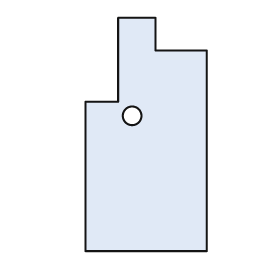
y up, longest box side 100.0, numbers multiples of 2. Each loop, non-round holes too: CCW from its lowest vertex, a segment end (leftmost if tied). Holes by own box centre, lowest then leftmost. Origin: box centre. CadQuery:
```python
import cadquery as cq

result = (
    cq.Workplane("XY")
    .moveTo(-26.0, -50.0)
    .lineTo(26.0, -50.0)
    .lineTo(26.0, 36.0)
    .lineTo(4.0, 36.0)
    .lineTo(4.0, 50.0)
    .lineTo(-12.0, 50.0)
    .lineTo(-12.0, 14.0)
    .lineTo(-26.0, 14.0)
    .close()
    .moveTo(-6.0, 8.0)
    .circle(4.0)
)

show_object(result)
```